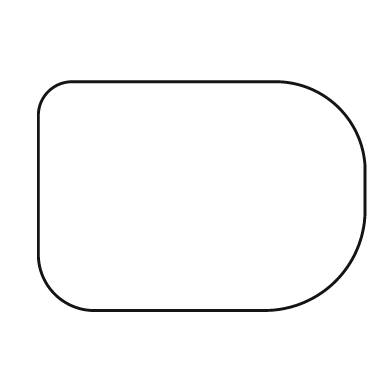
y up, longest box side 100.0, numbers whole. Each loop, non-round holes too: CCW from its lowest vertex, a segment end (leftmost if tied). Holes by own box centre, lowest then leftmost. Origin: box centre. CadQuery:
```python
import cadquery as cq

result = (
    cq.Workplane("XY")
    .moveTo(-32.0, -35.0)
    .lineTo(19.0, -35.0)
    .threePointArc((41.0, -26.0), (50.0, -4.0))
    .lineTo(50.0, 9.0)
    .threePointArc((42.0, 27.0), (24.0, 35.0))
    .lineTo(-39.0, 35.0)
    .threePointArc((-47.0, 32.0), (-50.0, 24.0))
    .lineTo(-50.0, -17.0)
    .threePointArc((-45.0, -30.0), (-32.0, -35.0))
    .close()
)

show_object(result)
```